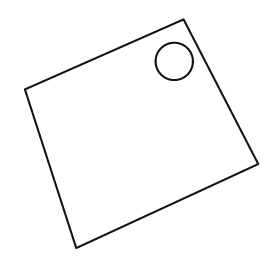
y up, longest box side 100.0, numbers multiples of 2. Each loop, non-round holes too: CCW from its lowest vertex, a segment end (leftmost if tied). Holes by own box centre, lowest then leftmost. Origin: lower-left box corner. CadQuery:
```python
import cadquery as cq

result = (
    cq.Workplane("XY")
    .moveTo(22.0, 0.0)
    .lineTo(100.0, 36.0)
    .lineTo(68.0, 98.0)
    .lineTo(0.0, 68.0)
    .close()
    .moveTo(64.0, 80.0)
    .circle(8.0)
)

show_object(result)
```